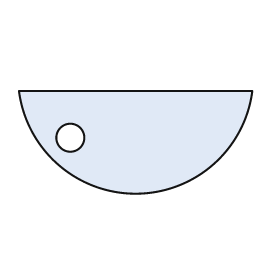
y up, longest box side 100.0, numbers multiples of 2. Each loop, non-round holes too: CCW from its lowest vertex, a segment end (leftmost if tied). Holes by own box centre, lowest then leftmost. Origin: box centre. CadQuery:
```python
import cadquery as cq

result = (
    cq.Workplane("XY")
    .moveTo(-50.0, 22.0)
    .threePointArc((0.0, -22.0), (50.0, 22.0))
    .close()
    .moveTo(-28.0, 2.0)
    .circle(6.0)
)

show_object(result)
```